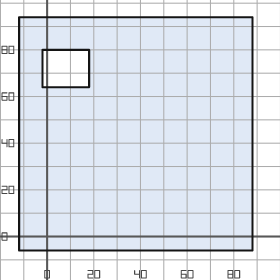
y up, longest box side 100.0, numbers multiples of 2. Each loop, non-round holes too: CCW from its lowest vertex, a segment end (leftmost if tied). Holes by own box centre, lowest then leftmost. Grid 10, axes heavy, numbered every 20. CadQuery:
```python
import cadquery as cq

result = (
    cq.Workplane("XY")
    .moveTo(-12.0, -6.0)
    .lineTo(88.0, -6.0)
    .lineTo(88.0, 94.0)
    .lineTo(-12.0, 94.0)
    .close()
    .moveTo(-2.0, 64.0)
    .lineTo(18.0, 64.0)
    .lineTo(18.0, 80.0)
    .lineTo(-2.0, 80.0)
    .close()
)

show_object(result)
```